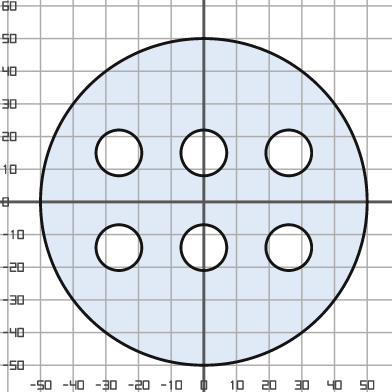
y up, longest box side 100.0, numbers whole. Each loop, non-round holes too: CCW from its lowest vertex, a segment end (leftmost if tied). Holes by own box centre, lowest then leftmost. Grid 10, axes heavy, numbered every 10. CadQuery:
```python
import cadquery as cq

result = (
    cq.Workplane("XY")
    .moveTo(0.0, 0.0)
    .circle(50.0)
    .moveTo(-26.0, -14.0)
    .circle(7.0)
    .moveTo(0.0, -14.0)
    .circle(7.0)
    .moveTo(26.0, -14.0)
    .circle(7.0)
    .moveTo(-26.0, 15.0)
    .circle(7.0)
    .moveTo(0.0, 15.0)
    .circle(7.0)
    .moveTo(26.0, 15.0)
    .circle(7.0)
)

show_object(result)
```